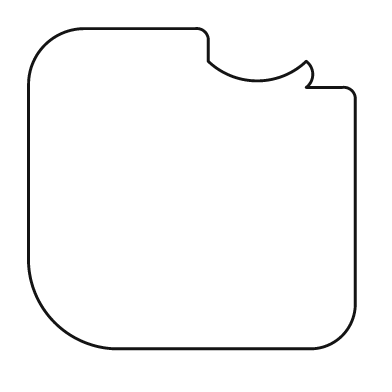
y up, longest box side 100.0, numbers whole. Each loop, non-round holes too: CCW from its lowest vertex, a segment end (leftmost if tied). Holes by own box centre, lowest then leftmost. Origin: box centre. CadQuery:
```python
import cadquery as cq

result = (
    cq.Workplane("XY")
    .moveTo(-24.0, -49.0)
    .lineTo(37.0, -49.0)
    .threePointArc((46.0, -45.0), (50.0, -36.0))
    .lineTo(50.0, 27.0)
    .threePointArc((49.0, 30.0), (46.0, 31.0))
    .lineTo(35.0, 31.0)
    .threePointArc((37.0, 35.0), (35.0, 39.0))
    .threePointArc((20.0, 33.0), (5.0, 39.0))
    .lineTo(5.0, 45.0)
    .threePointArc((4.0, 48.0), (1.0, 49.0))
    .lineTo(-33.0, 49.0)
    .threePointArc((-45.0, 44.0), (-50.0, 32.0))
    .lineTo(-50.0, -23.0)
    .threePointArc((-42.0, -41.0), (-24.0, -49.0))
    .close()
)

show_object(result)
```